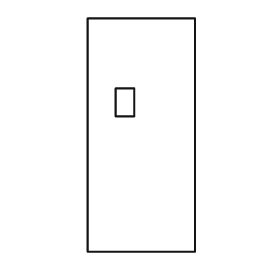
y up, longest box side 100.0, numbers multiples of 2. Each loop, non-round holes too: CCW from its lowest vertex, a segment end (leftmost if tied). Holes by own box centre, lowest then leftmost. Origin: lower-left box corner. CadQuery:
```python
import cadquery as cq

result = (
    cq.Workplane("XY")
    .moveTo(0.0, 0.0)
    .lineTo(46.0, 0.0)
    .lineTo(46.0, 100.0)
    .lineTo(0.0, 100.0)
    .close()
    .moveTo(12.0, 58.0)
    .lineTo(20.0, 58.0)
    .lineTo(20.0, 70.0)
    .lineTo(12.0, 70.0)
    .close()
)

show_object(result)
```